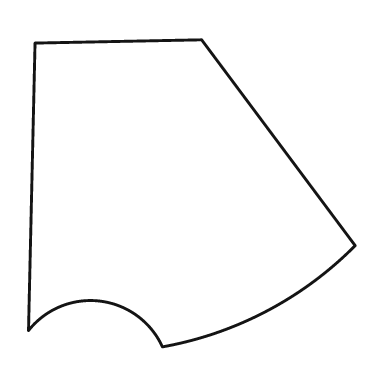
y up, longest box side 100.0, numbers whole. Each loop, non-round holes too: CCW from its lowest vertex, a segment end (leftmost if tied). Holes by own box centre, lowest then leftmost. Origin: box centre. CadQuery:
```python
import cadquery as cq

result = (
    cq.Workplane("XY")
    .moveTo(-9.0, -47.0)
    .threePointArc((23.0, -36.0), (50.0, -16.0))
    .lineTo(3.0, 47.0)
    .lineTo(-48.0, 46.0)
    .lineTo(-50.0, -42.0)
    .threePointArc((-28.0, -33.0), (-9.0, -47.0))
    .close()
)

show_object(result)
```